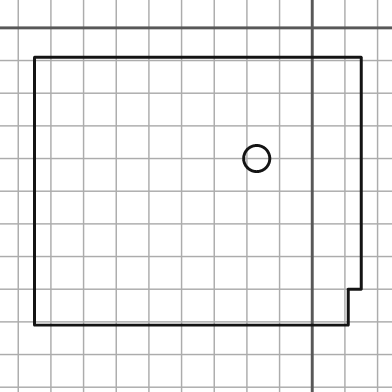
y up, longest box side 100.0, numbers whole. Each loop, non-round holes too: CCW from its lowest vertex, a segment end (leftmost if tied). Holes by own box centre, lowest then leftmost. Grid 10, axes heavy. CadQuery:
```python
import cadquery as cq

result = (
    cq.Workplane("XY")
    .moveTo(-85.0, -91.0)
    .lineTo(11.0, -91.0)
    .lineTo(11.0, -80.0)
    .lineTo(15.0, -80.0)
    .lineTo(15.0, -9.0)
    .lineTo(-85.0, -9.0)
    .close()
    .moveTo(-17.0, -40.0)
    .circle(4.0)
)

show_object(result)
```